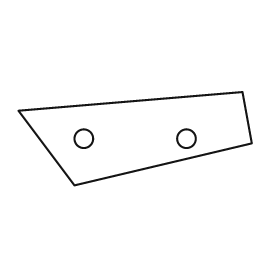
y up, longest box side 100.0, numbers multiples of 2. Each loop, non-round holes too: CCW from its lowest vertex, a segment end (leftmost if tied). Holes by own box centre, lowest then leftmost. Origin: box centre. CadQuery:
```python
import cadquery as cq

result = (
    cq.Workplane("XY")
    .moveTo(-26.0, -20.0)
    .lineTo(50.0, -2.0)
    .lineTo(46.0, 20.0)
    .lineTo(-50.0, 12.0)
    .close()
    .moveTo(-22.0, 0.0)
    .circle(4.0)
    .moveTo(22.0, 0.0)
    .circle(4.0)
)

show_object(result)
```